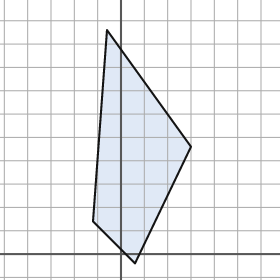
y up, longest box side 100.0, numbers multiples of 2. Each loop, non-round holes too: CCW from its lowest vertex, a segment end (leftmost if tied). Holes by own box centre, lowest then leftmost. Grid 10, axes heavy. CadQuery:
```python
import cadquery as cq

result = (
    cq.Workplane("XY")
    .moveTo(6.0, -4.0)
    .lineTo(30.0, 46.0)
    .lineTo(-6.0, 96.0)
    .lineTo(-12.0, 14.0)
    .close()
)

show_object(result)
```